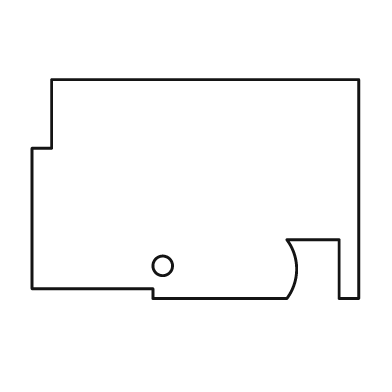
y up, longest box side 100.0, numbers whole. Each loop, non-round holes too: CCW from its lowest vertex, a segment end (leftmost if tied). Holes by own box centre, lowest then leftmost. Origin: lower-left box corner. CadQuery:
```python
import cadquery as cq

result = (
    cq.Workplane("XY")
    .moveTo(37.0, 0.0)
    .lineTo(78.0, 0.0)
    .threePointArc((81.0, 9.0), (78.0, 18.0))
    .lineTo(94.0, 18.0)
    .lineTo(94.0, 0.0)
    .lineTo(100.0, 0.0)
    .lineTo(100.0, 67.0)
    .lineTo(6.0, 67.0)
    .lineTo(6.0, 46.0)
    .lineTo(0.0, 46.0)
    .lineTo(0.0, 3.0)
    .lineTo(37.0, 3.0)
    .close()
    .moveTo(40.0, 10.0)
    .circle(3.0)
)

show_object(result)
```